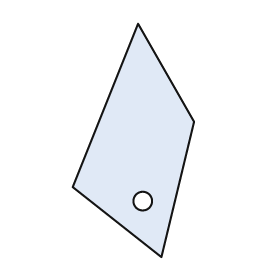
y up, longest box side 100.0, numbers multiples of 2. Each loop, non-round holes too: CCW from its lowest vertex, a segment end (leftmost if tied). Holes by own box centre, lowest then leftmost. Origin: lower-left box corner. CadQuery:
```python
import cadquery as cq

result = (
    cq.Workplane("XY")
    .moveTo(38.0, 0.0)
    .lineTo(52.0, 58.0)
    .lineTo(28.0, 100.0)
    .lineTo(0.0, 30.0)
    .close()
    .moveTo(30.0, 24.0)
    .circle(4.0)
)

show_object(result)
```